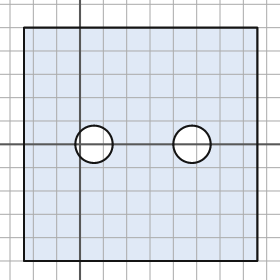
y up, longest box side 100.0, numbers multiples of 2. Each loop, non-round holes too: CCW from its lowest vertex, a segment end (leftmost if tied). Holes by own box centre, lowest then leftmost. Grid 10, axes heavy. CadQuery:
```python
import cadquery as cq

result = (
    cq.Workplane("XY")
    .moveTo(-24.0, -50.0)
    .lineTo(76.0, -50.0)
    .lineTo(76.0, 50.0)
    .lineTo(-24.0, 50.0)
    .close()
    .moveTo(6.0, 0.0)
    .circle(8.0)
    .moveTo(48.0, 0.0)
    .circle(8.0)
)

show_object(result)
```